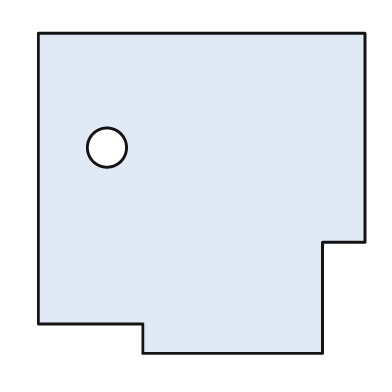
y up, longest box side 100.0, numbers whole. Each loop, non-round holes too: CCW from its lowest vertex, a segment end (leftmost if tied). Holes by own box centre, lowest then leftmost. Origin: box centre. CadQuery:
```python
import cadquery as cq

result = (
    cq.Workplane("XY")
    .moveTo(-18.0, -49.0)
    .lineTo(37.0, -49.0)
    .lineTo(37.0, -15.0)
    .lineTo(50.0, -15.0)
    .lineTo(50.0, 49.0)
    .lineTo(-50.0, 49.0)
    .lineTo(-50.0, -40.0)
    .lineTo(-18.0, -40.0)
    .close()
    .moveTo(-29.0, 14.0)
    .circle(6.0)
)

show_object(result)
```